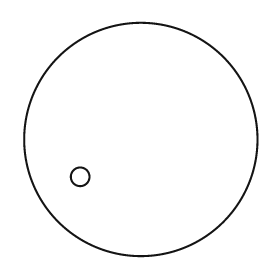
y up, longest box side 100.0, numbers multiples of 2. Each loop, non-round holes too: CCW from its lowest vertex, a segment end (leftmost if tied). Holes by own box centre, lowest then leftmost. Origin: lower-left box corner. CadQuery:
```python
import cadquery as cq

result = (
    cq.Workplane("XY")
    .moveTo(50.0, 50.0)
    .circle(50.0)
    .moveTo(24.0, 34.0)
    .circle(4.0)
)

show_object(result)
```